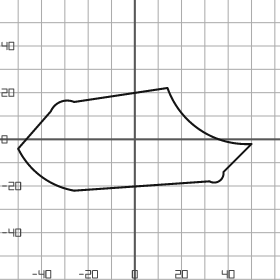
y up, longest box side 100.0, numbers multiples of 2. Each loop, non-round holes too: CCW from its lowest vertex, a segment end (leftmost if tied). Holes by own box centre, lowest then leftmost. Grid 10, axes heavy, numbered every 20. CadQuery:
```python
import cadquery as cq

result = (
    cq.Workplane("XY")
    .moveTo(-26.0, -22.0)
    .lineTo(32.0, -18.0)
    .threePointArc((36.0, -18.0), (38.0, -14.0))
    .lineTo(50.0, -2.0)
    .threePointArc((28.0, 4.0), (14.0, 22.0))
    .lineTo(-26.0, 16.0)
    .threePointArc((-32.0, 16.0), (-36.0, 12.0))
    .lineTo(-50.0, -4.0)
    .threePointArc((-40.0, -16.0), (-26.0, -22.0))
    .close()
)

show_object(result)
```